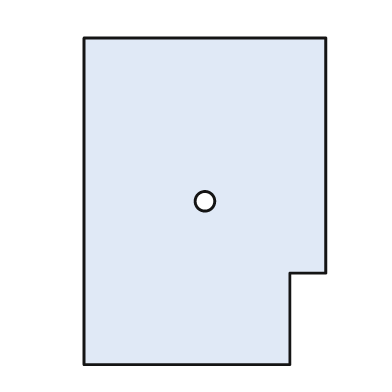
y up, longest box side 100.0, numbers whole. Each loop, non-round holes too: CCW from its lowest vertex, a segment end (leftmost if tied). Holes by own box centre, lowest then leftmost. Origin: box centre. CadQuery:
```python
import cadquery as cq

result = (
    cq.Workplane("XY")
    .moveTo(-37.0, -50.0)
    .lineTo(26.0, -50.0)
    .lineTo(26.0, -22.0)
    .lineTo(37.0, -22.0)
    .lineTo(37.0, 50.0)
    .lineTo(-37.0, 50.0)
    .close()
    .moveTo(0.0, 0.0)
    .circle(3.0)
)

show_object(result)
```